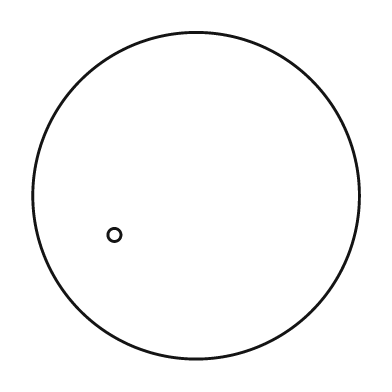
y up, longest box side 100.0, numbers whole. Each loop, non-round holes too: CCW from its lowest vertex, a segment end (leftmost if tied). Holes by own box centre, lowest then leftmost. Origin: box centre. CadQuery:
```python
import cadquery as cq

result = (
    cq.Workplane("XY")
    .moveTo(0.0, 0.0)
    .circle(50.0)
    .moveTo(-25.0, -12.0)
    .circle(2.0)
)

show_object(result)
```